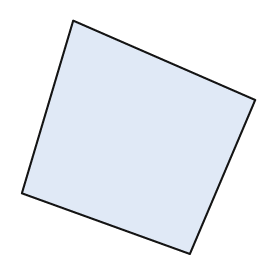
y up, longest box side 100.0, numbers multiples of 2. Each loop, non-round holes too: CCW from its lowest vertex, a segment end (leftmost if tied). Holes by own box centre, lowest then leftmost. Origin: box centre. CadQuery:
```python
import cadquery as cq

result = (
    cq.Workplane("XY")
    .moveTo(22.0, -50.0)
    .lineTo(50.0, 16.0)
    .lineTo(-28.0, 50.0)
    .lineTo(-50.0, -24.0)
    .close()
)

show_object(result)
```